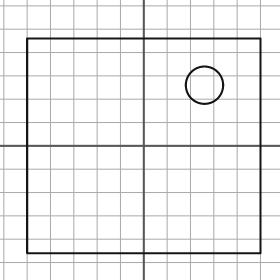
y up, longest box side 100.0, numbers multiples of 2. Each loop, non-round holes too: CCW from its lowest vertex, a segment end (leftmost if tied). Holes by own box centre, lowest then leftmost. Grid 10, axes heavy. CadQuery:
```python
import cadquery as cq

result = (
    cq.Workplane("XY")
    .moveTo(-50.0, -46.0)
    .lineTo(50.0, -46.0)
    .lineTo(50.0, 46.0)
    .lineTo(-50.0, 46.0)
    .close()
    .moveTo(26.0, 26.0)
    .circle(8.0)
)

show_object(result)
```